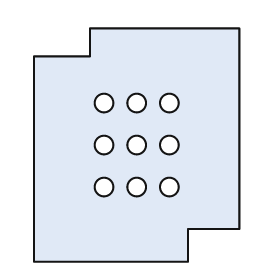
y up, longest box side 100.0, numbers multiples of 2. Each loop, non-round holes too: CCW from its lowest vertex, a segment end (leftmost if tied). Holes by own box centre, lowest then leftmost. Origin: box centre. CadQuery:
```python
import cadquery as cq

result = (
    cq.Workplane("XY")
    .moveTo(-44.0, -50.0)
    .lineTo(22.0, -50.0)
    .lineTo(22.0, -36.0)
    .lineTo(44.0, -36.0)
    .lineTo(44.0, 50.0)
    .lineTo(-20.0, 50.0)
    .lineTo(-20.0, 38.0)
    .lineTo(-44.0, 38.0)
    .close()
    .moveTo(-14.0, -18.0)
    .circle(4.0)
    .moveTo(0.0, -18.0)
    .circle(4.0)
    .moveTo(14.0, -18.0)
    .circle(4.0)
    .moveTo(-14.0, 0.0)
    .circle(4.0)
    .moveTo(0.0, 0.0)
    .circle(4.0)
    .moveTo(14.0, 0.0)
    .circle(4.0)
    .moveTo(-14.0, 18.0)
    .circle(4.0)
    .moveTo(0.0, 18.0)
    .circle(4.0)
    .moveTo(14.0, 18.0)
    .circle(4.0)
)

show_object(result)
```